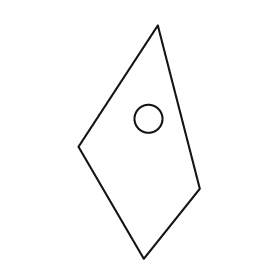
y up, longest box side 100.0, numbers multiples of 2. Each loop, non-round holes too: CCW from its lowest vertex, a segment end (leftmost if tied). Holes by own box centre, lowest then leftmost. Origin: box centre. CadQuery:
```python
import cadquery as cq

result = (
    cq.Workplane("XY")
    .moveTo(2.0, -50.0)
    .lineTo(26.0, -20.0)
    .lineTo(8.0, 50.0)
    .lineTo(-26.0, -2.0)
    .close()
    .moveTo(4.0, 10.0)
    .circle(6.0)
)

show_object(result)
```